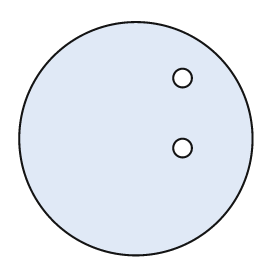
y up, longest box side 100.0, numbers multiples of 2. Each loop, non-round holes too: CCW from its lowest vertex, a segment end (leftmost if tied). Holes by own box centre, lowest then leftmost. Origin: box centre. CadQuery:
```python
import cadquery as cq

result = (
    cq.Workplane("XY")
    .moveTo(0.0, 0.0)
    .circle(50.0)
    .moveTo(20.0, -4.0)
    .circle(4.0)
    .moveTo(20.0, 26.0)
    .circle(4.0)
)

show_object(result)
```